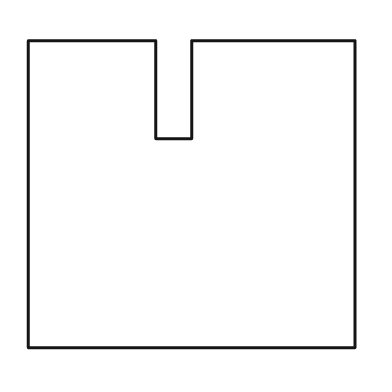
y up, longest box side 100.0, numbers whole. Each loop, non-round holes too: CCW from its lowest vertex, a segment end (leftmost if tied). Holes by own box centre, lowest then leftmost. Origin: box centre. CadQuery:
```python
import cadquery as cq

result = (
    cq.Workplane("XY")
    .moveTo(-50.0, -47.0)
    .lineTo(50.0, -47.0)
    .lineTo(50.0, 47.0)
    .lineTo(0.0, 47.0)
    .lineTo(0.0, 17.0)
    .lineTo(-11.0, 17.0)
    .lineTo(-11.0, 47.0)
    .lineTo(-50.0, 47.0)
    .close()
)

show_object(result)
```